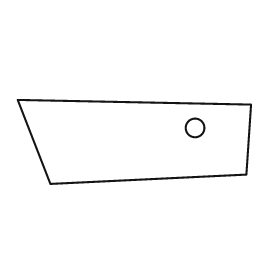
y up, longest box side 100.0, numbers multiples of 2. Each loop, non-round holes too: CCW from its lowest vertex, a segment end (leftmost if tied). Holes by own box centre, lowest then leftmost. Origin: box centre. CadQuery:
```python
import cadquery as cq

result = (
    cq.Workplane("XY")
    .moveTo(-36.0, -18.0)
    .lineTo(48.0, -14.0)
    .lineTo(50.0, 16.0)
    .lineTo(-50.0, 18.0)
    .close()
    .moveTo(26.0, 6.0)
    .circle(4.0)
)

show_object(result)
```